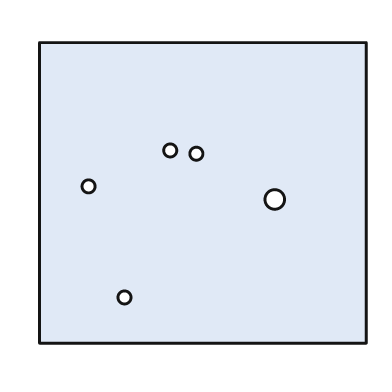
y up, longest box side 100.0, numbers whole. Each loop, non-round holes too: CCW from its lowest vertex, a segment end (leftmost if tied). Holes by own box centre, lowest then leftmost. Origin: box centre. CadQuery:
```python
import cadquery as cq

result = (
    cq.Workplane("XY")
    .moveTo(-50.0, -46.0)
    .lineTo(50.0, -46.0)
    .lineTo(50.0, 46.0)
    .lineTo(-50.0, 46.0)
    .close()
    .moveTo(-24.0, -32.0)
    .circle(2.0)
    .moveTo(22.0, -2.0)
    .circle(3.0)
    .moveTo(-35.0, 2.0)
    .circle(2.0)
    .moveTo(-2.0, 12.0)
    .circle(2.0)
    .moveTo(-10.0, 13.0)
    .circle(2.0)
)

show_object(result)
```